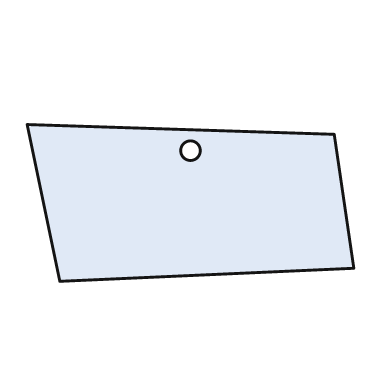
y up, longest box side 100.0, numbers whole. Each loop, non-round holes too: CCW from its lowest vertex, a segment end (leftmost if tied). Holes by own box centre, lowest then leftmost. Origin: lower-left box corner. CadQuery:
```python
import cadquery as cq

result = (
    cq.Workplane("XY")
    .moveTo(10.0, 0.0)
    .lineTo(100.0, 4.0)
    .lineTo(94.0, 45.0)
    .lineTo(0.0, 48.0)
    .close()
    .moveTo(50.0, 40.0)
    .circle(3.0)
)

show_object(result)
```